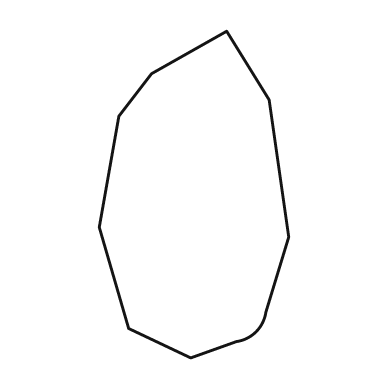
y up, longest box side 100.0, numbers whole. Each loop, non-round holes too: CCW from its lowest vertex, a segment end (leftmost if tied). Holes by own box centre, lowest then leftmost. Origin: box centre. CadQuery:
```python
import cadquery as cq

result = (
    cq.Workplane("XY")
    .moveTo(-1.0, -50.0)
    .lineTo(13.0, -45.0)
    .threePointArc((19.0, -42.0), (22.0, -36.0))
    .lineTo(29.0, -13.0)
    .lineTo(23.0, 29.0)
    .lineTo(10.0, 50.0)
    .lineTo(-13.0, 37.0)
    .lineTo(-23.0, 24.0)
    .lineTo(-29.0, -10.0)
    .lineTo(-20.0, -41.0)
    .close()
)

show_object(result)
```